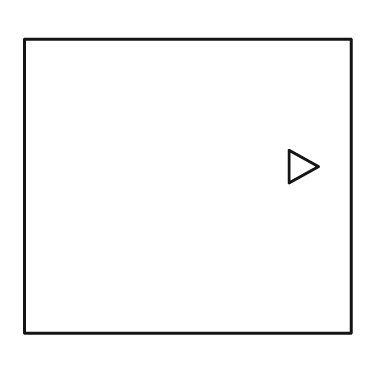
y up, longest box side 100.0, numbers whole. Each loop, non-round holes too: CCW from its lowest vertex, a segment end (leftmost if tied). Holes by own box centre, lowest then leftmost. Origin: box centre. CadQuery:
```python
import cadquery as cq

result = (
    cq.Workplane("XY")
    .moveTo(-50.0, -45.0)
    .lineTo(50.0, -45.0)
    .lineTo(50.0, 45.0)
    .lineTo(-50.0, 45.0)
    .close()
    .moveTo(31.0, 1.0)
    .lineTo(40.0, 6.0)
    .lineTo(31.0, 11.0)
    .close()
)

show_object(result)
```